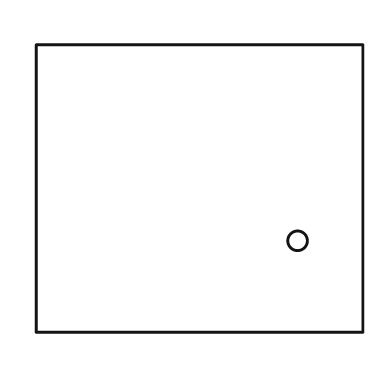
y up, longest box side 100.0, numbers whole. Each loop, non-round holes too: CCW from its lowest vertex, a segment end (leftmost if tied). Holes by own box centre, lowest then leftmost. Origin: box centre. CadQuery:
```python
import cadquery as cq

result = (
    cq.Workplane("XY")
    .moveTo(-50.0, -44.0)
    .lineTo(50.0, -44.0)
    .lineTo(50.0, 44.0)
    .lineTo(-50.0, 44.0)
    .close()
    .moveTo(30.0, -16.0)
    .circle(3.0)
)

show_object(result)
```